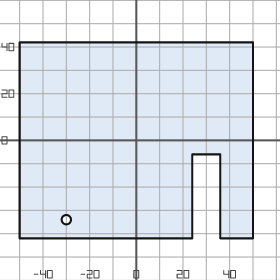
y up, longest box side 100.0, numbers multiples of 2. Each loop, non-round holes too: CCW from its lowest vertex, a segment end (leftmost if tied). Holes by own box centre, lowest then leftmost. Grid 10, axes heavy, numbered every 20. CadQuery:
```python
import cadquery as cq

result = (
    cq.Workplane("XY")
    .moveTo(-50.0, -42.0)
    .lineTo(24.0, -42.0)
    .lineTo(24.0, -6.0)
    .lineTo(36.0, -6.0)
    .lineTo(36.0, -42.0)
    .lineTo(50.0, -42.0)
    .lineTo(50.0, 42.0)
    .lineTo(-50.0, 42.0)
    .close()
    .moveTo(-30.0, -34.0)
    .circle(2.0)
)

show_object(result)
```